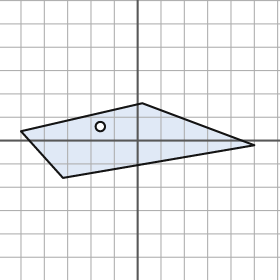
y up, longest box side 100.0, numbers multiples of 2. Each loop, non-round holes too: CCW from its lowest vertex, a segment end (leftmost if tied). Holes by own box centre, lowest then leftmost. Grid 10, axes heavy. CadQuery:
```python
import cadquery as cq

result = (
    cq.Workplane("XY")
    .moveTo(-32.0, -16.0)
    .lineTo(50.0, -2.0)
    .lineTo(2.0, 16.0)
    .lineTo(-50.0, 4.0)
    .close()
    .moveTo(-16.0, 6.0)
    .circle(2.0)
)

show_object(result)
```